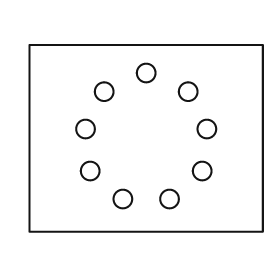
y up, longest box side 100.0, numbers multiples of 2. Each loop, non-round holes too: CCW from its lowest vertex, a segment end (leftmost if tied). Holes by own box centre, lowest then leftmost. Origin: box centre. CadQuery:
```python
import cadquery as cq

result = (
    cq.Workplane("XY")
    .moveTo(-50.0, -40.0)
    .lineTo(50.0, -40.0)
    .lineTo(50.0, 40.0)
    .lineTo(-50.0, 40.0)
    .close()
    .moveTo(-10.0, -26.0)
    .circle(4.0)
    .moveTo(10.0, -26.0)
    .circle(4.0)
    .moveTo(-24.0, -14.0)
    .circle(4.0)
    .moveTo(24.0, -14.0)
    .circle(4.0)
    .moveTo(-26.0, 4.0)
    .circle(4.0)
    .moveTo(26.0, 4.0)
    .circle(4.0)
    .moveTo(-18.0, 20.0)
    .circle(4.0)
    .moveTo(18.0, 20.0)
    .circle(4.0)
    .moveTo(0.0, 28.0)
    .circle(4.0)
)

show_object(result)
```